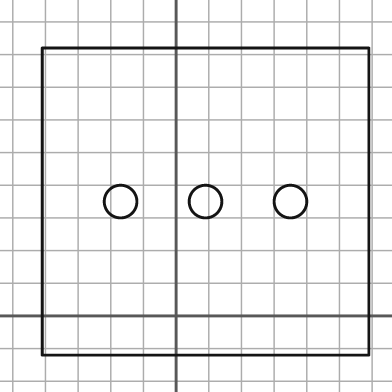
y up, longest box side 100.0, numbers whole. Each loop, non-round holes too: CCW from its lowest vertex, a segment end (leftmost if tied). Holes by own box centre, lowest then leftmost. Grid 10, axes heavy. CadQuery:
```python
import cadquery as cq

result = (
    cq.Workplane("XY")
    .moveTo(-41.0, -12.0)
    .lineTo(59.0, -12.0)
    .lineTo(59.0, 82.0)
    .lineTo(-41.0, 82.0)
    .close()
    .moveTo(-17.0, 35.0)
    .circle(5.0)
    .moveTo(9.0, 35.0)
    .circle(5.0)
    .moveTo(35.0, 35.0)
    .circle(5.0)
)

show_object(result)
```